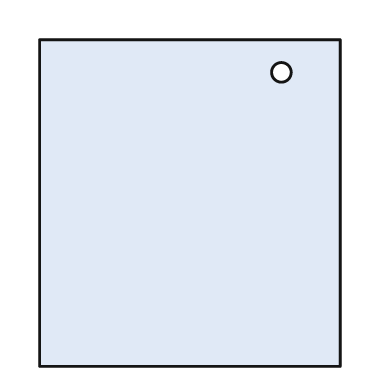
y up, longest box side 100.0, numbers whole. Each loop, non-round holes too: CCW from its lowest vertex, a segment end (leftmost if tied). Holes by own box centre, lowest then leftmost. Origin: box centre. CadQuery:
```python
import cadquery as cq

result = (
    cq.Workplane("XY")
    .moveTo(-46.0, -50.0)
    .lineTo(46.0, -50.0)
    .lineTo(46.0, 50.0)
    .lineTo(-46.0, 50.0)
    .close()
    .moveTo(28.0, 40.0)
    .circle(3.0)
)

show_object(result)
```